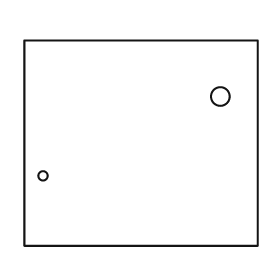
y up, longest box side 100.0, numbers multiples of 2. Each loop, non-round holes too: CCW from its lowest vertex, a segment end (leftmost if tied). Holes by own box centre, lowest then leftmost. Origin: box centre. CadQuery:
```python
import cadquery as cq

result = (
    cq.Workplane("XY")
    .moveTo(-50.0, -44.0)
    .lineTo(50.0, -44.0)
    .lineTo(50.0, 44.0)
    .lineTo(-50.0, 44.0)
    .close()
    .moveTo(-42.0, -14.0)
    .circle(2.0)
    .moveTo(34.0, 20.0)
    .circle(4.0)
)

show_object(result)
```